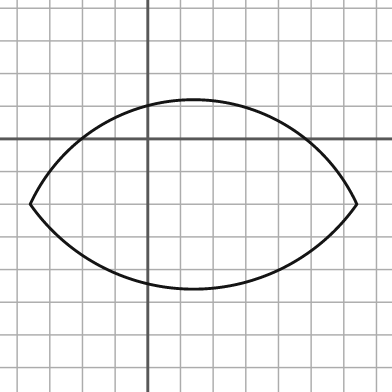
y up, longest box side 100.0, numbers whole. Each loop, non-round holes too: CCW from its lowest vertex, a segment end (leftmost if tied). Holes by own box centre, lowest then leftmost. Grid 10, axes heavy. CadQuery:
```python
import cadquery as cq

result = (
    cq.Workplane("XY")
    .moveTo(-36.0, -20.0)
    .threePointArc((14.0, -46.0), (64.0, -20.0))
    .threePointArc((14.0, 12.0), (-36.0, -20.0))
    .close()
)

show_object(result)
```